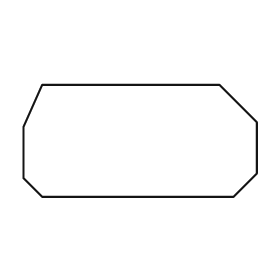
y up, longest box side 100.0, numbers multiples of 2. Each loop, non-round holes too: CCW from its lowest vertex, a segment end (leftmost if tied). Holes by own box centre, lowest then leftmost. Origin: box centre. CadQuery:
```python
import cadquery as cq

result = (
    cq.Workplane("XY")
    .moveTo(-42.0, -24.0)
    .lineTo(40.0, -24.0)
    .lineTo(50.0, -14.0)
    .lineTo(50.0, 8.0)
    .lineTo(34.0, 24.0)
    .lineTo(-42.0, 24.0)
    .lineTo(-50.0, 6.0)
    .lineTo(-50.0, -16.0)
    .close()
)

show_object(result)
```